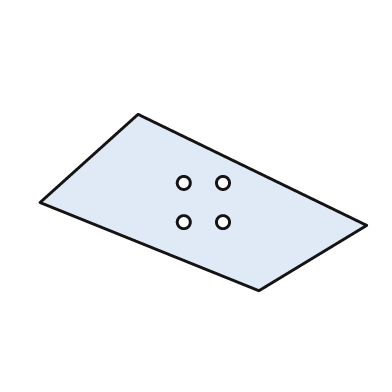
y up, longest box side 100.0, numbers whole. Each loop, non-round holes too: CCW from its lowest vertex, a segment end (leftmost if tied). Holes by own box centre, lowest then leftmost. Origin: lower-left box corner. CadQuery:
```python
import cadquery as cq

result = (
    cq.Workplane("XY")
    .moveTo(67.0, 0.0)
    .lineTo(100.0, 20.0)
    .lineTo(30.0, 54.0)
    .lineTo(0.0, 27.0)
    .close()
    .moveTo(44.0, 21.0)
    .circle(2.0)
    .moveTo(56.0, 21.0)
    .circle(2.0)
    .moveTo(44.0, 33.0)
    .circle(2.0)
    .moveTo(56.0, 33.0)
    .circle(2.0)
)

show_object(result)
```